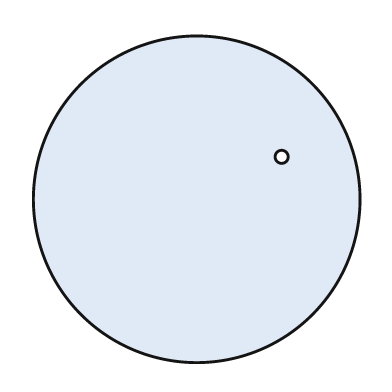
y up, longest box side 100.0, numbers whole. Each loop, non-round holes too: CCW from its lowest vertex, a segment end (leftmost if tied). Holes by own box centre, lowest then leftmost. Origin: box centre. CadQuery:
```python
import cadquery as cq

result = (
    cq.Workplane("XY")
    .moveTo(0.0, 0.0)
    .circle(50.0)
    .moveTo(26.0, 13.0)
    .circle(2.0)
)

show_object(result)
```